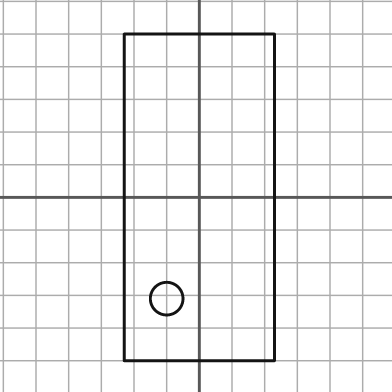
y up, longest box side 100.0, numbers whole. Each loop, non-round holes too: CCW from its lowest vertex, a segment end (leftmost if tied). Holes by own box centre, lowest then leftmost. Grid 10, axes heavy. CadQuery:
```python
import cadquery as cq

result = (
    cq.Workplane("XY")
    .moveTo(-23.0, -50.0)
    .lineTo(23.0, -50.0)
    .lineTo(23.0, 50.0)
    .lineTo(-23.0, 50.0)
    .close()
    .moveTo(-10.0, -31.0)
    .circle(5.0)
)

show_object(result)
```